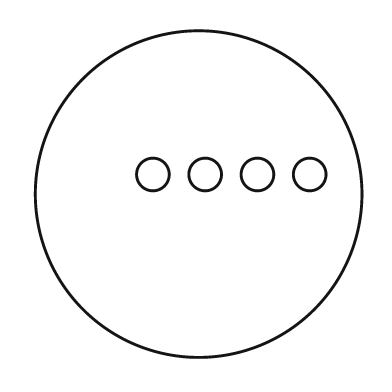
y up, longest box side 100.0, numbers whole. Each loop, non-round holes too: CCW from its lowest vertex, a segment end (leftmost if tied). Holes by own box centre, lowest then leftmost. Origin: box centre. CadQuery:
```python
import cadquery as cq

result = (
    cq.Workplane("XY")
    .moveTo(0.0, 0.0)
    .circle(50.0)
    .moveTo(-14.0, 6.0)
    .circle(5.0)
    .moveTo(2.0, 6.0)
    .circle(5.0)
    .moveTo(18.0, 6.0)
    .circle(5.0)
    .moveTo(34.0, 6.0)
    .circle(5.0)
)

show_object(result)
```